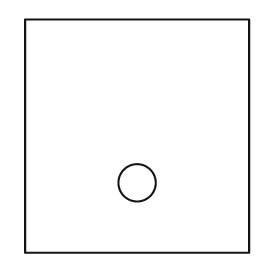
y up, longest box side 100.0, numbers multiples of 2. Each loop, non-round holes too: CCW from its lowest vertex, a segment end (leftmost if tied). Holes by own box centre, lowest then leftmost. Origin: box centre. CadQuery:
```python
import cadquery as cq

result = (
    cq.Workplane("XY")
    .moveTo(-48.0, -50.0)
    .lineTo(48.0, -50.0)
    .lineTo(48.0, 50.0)
    .lineTo(-48.0, 50.0)
    .close()
    .moveTo(0.0, -20.0)
    .circle(8.0)
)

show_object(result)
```